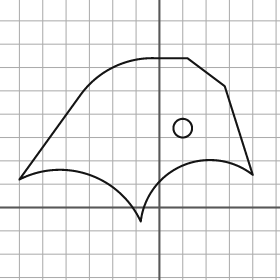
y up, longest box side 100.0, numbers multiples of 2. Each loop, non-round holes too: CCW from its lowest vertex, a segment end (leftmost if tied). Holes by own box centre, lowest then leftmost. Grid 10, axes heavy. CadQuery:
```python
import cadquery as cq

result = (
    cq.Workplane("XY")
    .moveTo(-8.0, -6.0)
    .threePointArc((10.0, 18.0), (40.0, 14.0))
    .lineTo(28.0, 52.0)
    .lineTo(12.0, 64.0)
    .lineTo(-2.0, 64.0)
    .threePointArc((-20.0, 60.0), (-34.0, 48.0))
    .lineTo(-60.0, 12.0)
    .threePointArc((-30.0, 14.0), (-8.0, -6.0))
    .close()
    .moveTo(10.0, 34.0)
    .circle(4.0)
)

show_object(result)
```